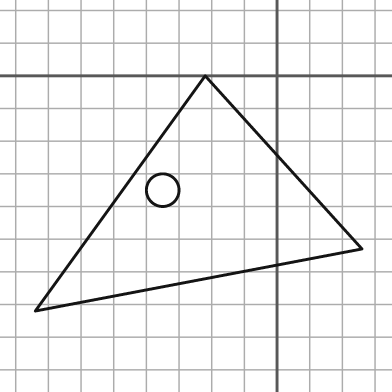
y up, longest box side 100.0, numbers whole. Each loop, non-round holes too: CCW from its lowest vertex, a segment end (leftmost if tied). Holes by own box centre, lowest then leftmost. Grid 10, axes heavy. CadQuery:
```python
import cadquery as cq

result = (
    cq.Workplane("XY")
    .moveTo(-74.0, -72.0)
    .lineTo(26.0, -53.0)
    .lineTo(-22.0, 0.0)
    .close()
    .moveTo(-35.0, -35.0)
    .circle(5.0)
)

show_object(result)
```